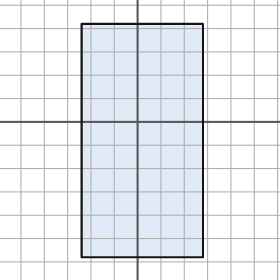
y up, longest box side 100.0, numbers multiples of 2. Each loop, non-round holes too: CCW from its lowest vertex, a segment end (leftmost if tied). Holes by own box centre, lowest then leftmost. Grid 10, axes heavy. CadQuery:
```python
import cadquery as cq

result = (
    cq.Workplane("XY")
    .moveTo(-24.0, -58.0)
    .lineTo(28.0, -58.0)
    .lineTo(28.0, 42.0)
    .lineTo(-24.0, 42.0)
    .close()
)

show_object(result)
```